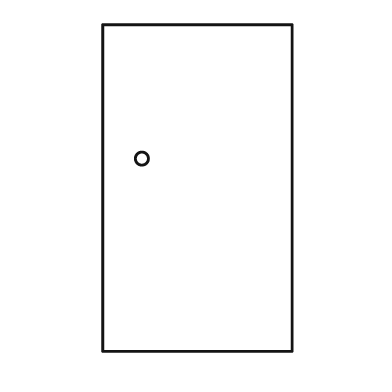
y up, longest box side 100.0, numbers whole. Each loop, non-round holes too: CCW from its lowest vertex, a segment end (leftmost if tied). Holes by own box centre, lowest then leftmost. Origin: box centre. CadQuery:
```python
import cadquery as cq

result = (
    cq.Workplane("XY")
    .moveTo(-29.0, -50.0)
    .lineTo(29.0, -50.0)
    .lineTo(29.0, 50.0)
    .lineTo(-29.0, 50.0)
    .close()
    .moveTo(-17.0, 9.0)
    .circle(2.0)
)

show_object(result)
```